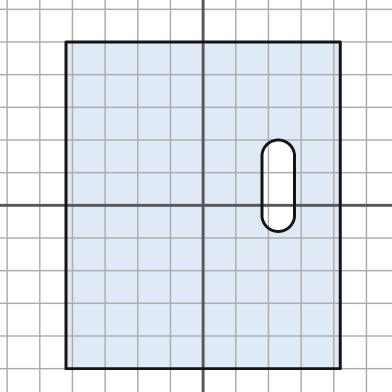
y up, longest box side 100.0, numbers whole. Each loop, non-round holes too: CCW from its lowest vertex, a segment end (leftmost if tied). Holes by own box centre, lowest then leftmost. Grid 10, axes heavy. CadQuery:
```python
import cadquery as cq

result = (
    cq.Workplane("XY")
    .moveTo(-42.0, -50.0)
    .lineTo(42.0, -50.0)
    .lineTo(42.0, 50.0)
    .lineTo(-42.0, 50.0)
    .close()
    .moveTo(18.0, -3.0)
    .threePointArc((23.0, -8.0), (28.0, -3.0))
    .lineTo(28.0, 15.0)
    .threePointArc((23.0, 20.0), (18.0, 15.0))
    .close()
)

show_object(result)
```